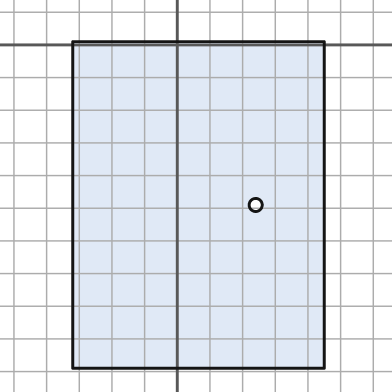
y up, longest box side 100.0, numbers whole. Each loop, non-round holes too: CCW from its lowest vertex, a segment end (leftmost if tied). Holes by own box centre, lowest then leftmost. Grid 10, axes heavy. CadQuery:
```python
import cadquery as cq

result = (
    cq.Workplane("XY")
    .moveTo(-32.0, -99.0)
    .lineTo(45.0, -99.0)
    .lineTo(45.0, 1.0)
    .lineTo(-32.0, 1.0)
    .close()
    .moveTo(24.0, -49.0)
    .circle(2.0)
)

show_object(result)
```